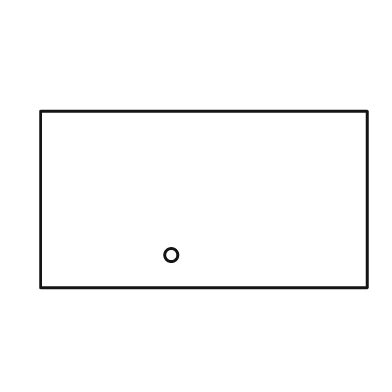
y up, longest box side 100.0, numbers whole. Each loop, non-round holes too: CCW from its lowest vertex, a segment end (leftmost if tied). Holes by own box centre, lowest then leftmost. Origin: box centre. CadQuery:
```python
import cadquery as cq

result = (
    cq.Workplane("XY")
    .moveTo(-50.0, -27.0)
    .lineTo(50.0, -27.0)
    .lineTo(50.0, 27.0)
    .lineTo(-50.0, 27.0)
    .close()
    .moveTo(-10.0, -17.0)
    .circle(2.0)
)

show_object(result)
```